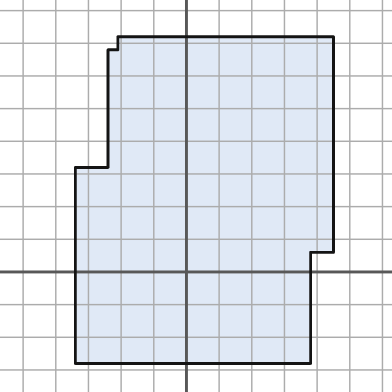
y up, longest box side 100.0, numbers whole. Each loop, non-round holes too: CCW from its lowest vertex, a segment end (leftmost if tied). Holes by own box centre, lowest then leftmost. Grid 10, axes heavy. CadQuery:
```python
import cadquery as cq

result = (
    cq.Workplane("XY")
    .moveTo(-34.0, -28.0)
    .lineTo(38.0, -28.0)
    .lineTo(38.0, 6.0)
    .lineTo(45.0, 6.0)
    .lineTo(45.0, 72.0)
    .lineTo(-21.0, 72.0)
    .lineTo(-21.0, 68.0)
    .lineTo(-24.0, 68.0)
    .lineTo(-24.0, 32.0)
    .lineTo(-34.0, 32.0)
    .close()
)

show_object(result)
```